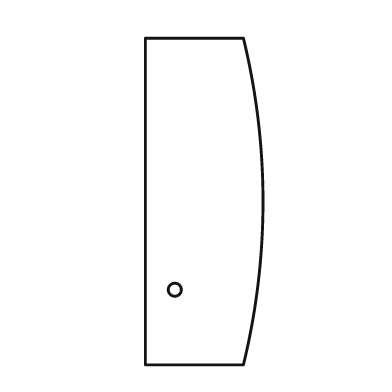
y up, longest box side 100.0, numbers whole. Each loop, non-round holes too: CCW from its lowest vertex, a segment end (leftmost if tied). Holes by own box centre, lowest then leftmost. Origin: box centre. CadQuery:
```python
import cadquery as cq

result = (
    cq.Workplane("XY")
    .moveTo(-18.0, -50.0)
    .lineTo(12.0, -50.0)
    .threePointArc((18.0, 0.0), (12.0, 50.0))
    .lineTo(-18.0, 50.0)
    .close()
    .moveTo(-9.0, -27.0)
    .circle(2.0)
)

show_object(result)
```